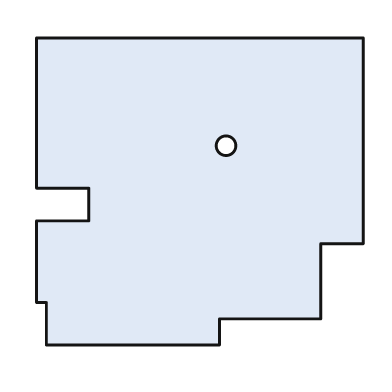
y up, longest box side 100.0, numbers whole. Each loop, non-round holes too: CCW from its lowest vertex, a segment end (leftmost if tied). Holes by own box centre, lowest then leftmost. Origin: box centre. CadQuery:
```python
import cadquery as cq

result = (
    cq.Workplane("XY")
    .moveTo(-47.0, -47.0)
    .lineTo(6.0, -47.0)
    .lineTo(6.0, -39.0)
    .lineTo(37.0, -39.0)
    .lineTo(37.0, -16.0)
    .lineTo(50.0, -16.0)
    .lineTo(50.0, 47.0)
    .lineTo(-50.0, 47.0)
    .lineTo(-50.0, 1.0)
    .lineTo(-34.0, 1.0)
    .lineTo(-34.0, -9.0)
    .lineTo(-50.0, -9.0)
    .lineTo(-50.0, -34.0)
    .lineTo(-47.0, -34.0)
    .close()
    .moveTo(8.0, 14.0)
    .circle(3.0)
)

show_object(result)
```